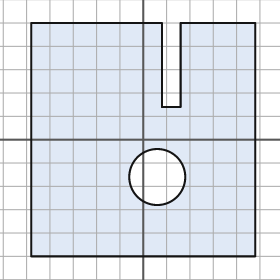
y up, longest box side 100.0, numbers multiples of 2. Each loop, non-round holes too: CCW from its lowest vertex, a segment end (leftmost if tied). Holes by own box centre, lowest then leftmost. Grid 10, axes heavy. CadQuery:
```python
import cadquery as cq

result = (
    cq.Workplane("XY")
    .moveTo(-48.0, -50.0)
    .lineTo(48.0, -50.0)
    .lineTo(48.0, 50.0)
    .lineTo(16.0, 50.0)
    .lineTo(16.0, 14.0)
    .lineTo(8.0, 14.0)
    .lineTo(8.0, 50.0)
    .lineTo(-48.0, 50.0)
    .close()
    .moveTo(6.0, -16.0)
    .circle(12.0)
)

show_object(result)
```